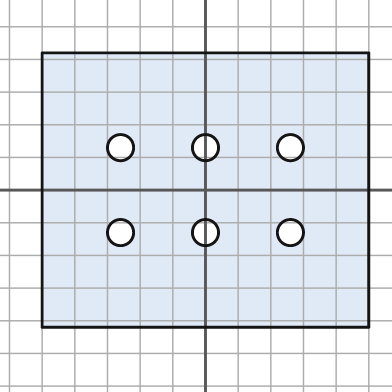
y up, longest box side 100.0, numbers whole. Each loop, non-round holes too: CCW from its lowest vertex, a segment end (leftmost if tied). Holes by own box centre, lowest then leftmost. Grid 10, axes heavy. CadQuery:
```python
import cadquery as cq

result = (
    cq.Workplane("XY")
    .moveTo(-50.0, -42.0)
    .lineTo(50.0, -42.0)
    .lineTo(50.0, 42.0)
    .lineTo(-50.0, 42.0)
    .close()
    .moveTo(-26.0, -13.0)
    .circle(4.0)
    .moveTo(0.0, -13.0)
    .circle(4.0)
    .moveTo(26.0, -13.0)
    .circle(4.0)
    .moveTo(-26.0, 13.0)
    .circle(4.0)
    .moveTo(0.0, 13.0)
    .circle(4.0)
    .moveTo(26.0, 13.0)
    .circle(4.0)
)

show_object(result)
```